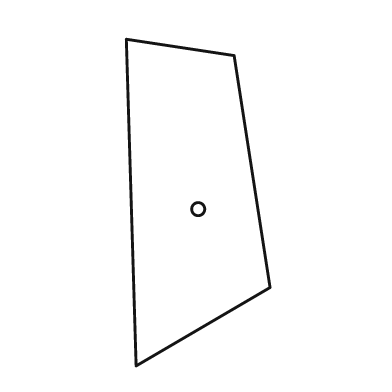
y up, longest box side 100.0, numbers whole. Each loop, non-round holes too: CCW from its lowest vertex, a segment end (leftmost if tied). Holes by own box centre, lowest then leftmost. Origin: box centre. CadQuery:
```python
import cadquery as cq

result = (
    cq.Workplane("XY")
    .moveTo(-19.0, -50.0)
    .lineTo(22.0, -26.0)
    .lineTo(11.0, 45.0)
    .lineTo(-22.0, 50.0)
    .close()
    .moveTo(0.0, -2.0)
    .circle(2.0)
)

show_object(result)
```